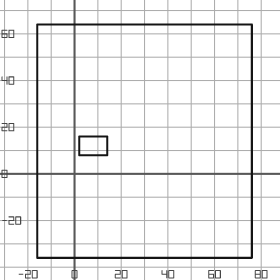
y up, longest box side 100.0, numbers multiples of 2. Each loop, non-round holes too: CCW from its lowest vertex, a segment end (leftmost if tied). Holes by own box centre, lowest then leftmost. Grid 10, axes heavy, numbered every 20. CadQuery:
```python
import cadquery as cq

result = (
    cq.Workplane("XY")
    .moveTo(-16.0, -36.0)
    .lineTo(76.0, -36.0)
    .lineTo(76.0, 64.0)
    .lineTo(-16.0, 64.0)
    .close()
    .moveTo(2.0, 8.0)
    .lineTo(14.0, 8.0)
    .lineTo(14.0, 16.0)
    .lineTo(2.0, 16.0)
    .close()
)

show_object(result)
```